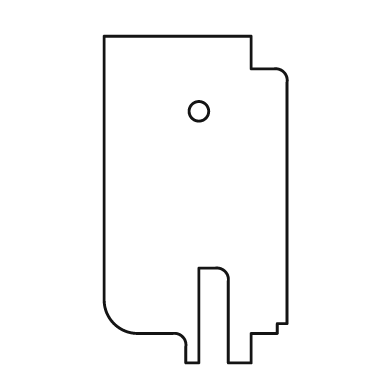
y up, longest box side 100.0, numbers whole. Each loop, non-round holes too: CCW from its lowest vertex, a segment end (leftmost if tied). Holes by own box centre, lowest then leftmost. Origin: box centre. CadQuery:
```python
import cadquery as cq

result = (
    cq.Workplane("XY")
    .moveTo(-3.0, -50.0)
    .lineTo(1.0, -50.0)
    .lineTo(1.0, -21.0)
    .lineTo(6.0, -21.0)
    .threePointArc((9.0, -22.0), (10.0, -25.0))
    .lineTo(10.0, -50.0)
    .lineTo(17.0, -50.0)
    .lineTo(17.0, -41.0)
    .lineTo(25.0, -41.0)
    .lineTo(25.0, -38.0)
    .lineTo(28.0, -38.0)
    .lineTo(28.0, 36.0)
    .threePointArc((27.0, 39.0), (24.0, 40.0))
    .lineTo(17.0, 40.0)
    .lineTo(17.0, 50.0)
    .lineTo(-28.0, 50.0)
    .lineTo(-28.0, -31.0)
    .threePointArc((-25.0, -38.0), (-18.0, -41.0))
    .lineTo(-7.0, -41.0)
    .threePointArc((-4.0, -42.0), (-3.0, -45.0))
    .close()
    .moveTo(1.0, 27.0)
    .circle(3.0)
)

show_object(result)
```